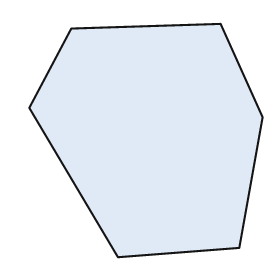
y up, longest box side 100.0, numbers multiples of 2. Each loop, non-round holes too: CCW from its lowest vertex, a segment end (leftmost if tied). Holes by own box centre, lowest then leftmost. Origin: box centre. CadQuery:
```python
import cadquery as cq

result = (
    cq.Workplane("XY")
    .moveTo(-12.0, -50.0)
    .lineTo(40.0, -46.0)
    .lineTo(50.0, 10.0)
    .lineTo(32.0, 50.0)
    .lineTo(-32.0, 48.0)
    .lineTo(-50.0, 14.0)
    .close()
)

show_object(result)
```